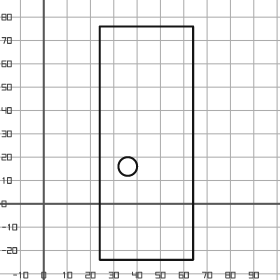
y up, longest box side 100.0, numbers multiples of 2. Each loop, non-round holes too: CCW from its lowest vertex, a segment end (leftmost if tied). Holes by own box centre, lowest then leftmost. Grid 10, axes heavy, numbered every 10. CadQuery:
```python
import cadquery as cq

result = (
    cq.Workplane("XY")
    .moveTo(24.0, -24.0)
    .lineTo(64.0, -24.0)
    .lineTo(64.0, 76.0)
    .lineTo(24.0, 76.0)
    .close()
    .moveTo(36.0, 16.0)
    .circle(4.0)
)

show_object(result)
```